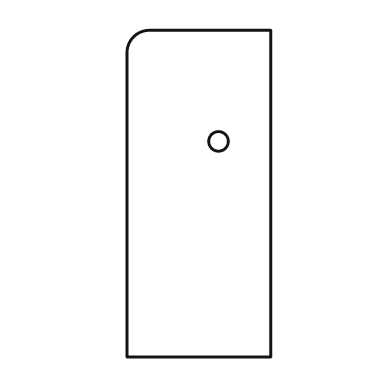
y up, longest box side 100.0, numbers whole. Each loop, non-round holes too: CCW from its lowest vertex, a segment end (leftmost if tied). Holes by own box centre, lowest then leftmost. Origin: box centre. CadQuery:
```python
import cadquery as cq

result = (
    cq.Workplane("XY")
    .moveTo(-22.0, -50.0)
    .lineTo(22.0, -50.0)
    .lineTo(22.0, 50.0)
    .lineTo(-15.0, 50.0)
    .threePointArc((-20.0, 48.0), (-22.0, 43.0))
    .close()
    .moveTo(6.0, 16.0)
    .circle(3.0)
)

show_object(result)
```